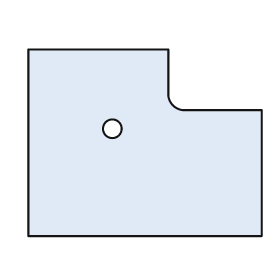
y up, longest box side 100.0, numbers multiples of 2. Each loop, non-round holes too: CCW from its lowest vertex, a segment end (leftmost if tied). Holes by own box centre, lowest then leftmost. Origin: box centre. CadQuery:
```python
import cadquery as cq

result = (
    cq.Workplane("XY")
    .moveTo(-50.0, -40.0)
    .lineTo(50.0, -40.0)
    .lineTo(50.0, 14.0)
    .lineTo(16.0, 14.0)
    .threePointArc((12.0, 16.0), (10.0, 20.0))
    .lineTo(10.0, 40.0)
    .lineTo(-50.0, 40.0)
    .close()
    .moveTo(-14.0, 6.0)
    .circle(4.0)
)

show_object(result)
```